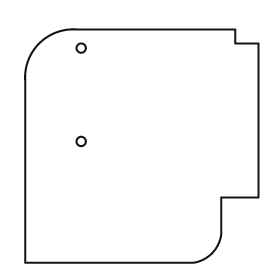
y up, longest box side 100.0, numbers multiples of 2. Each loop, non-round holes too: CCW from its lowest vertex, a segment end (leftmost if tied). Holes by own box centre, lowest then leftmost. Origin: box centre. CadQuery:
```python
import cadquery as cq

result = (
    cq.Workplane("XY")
    .moveTo(-50.0, -50.0)
    .lineTo(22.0, -50.0)
    .threePointArc((30.0, -46.0), (34.0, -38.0))
    .lineTo(34.0, -22.0)
    .lineTo(50.0, -22.0)
    .lineTo(50.0, 44.0)
    .lineTo(40.0, 44.0)
    .lineTo(40.0, 50.0)
    .lineTo(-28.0, 50.0)
    .threePointArc((-44.0, 44.0), (-50.0, 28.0))
    .close()
    .moveTo(-26.0, 2.0)
    .circle(2.0)
    .moveTo(-26.0, 42.0)
    .circle(2.0)
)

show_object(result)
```